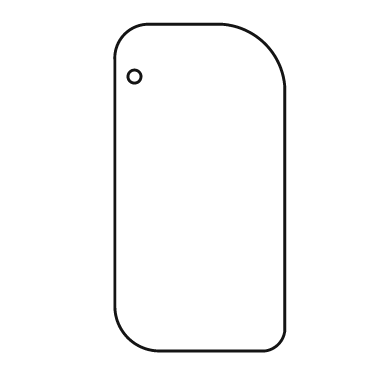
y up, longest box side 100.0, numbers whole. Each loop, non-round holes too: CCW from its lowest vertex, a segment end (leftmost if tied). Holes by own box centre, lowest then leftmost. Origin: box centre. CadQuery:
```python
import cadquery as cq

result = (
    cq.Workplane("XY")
    .moveTo(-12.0, -50.0)
    .lineTo(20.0, -50.0)
    .threePointArc((24.0, -48.0), (26.0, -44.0))
    .lineTo(26.0, 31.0)
    .threePointArc((20.0, 44.0), (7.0, 50.0))
    .lineTo(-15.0, 50.0)
    .threePointArc((-23.0, 47.0), (-26.0, 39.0))
    .lineTo(-26.0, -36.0)
    .threePointArc((-22.0, -46.0), (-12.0, -50.0))
    .close()
    .moveTo(-20.0, 34.0)
    .circle(2.0)
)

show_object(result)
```